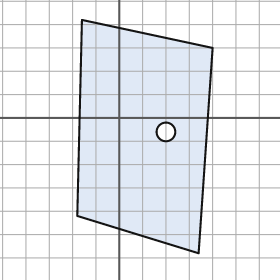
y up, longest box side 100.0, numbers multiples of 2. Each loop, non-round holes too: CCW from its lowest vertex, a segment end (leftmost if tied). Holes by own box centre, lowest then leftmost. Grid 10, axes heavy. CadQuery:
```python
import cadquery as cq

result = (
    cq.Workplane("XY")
    .moveTo(34.0, -58.0)
    .lineTo(40.0, 30.0)
    .lineTo(-16.0, 42.0)
    .lineTo(-18.0, -42.0)
    .close()
    .moveTo(20.0, -6.0)
    .circle(4.0)
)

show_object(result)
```